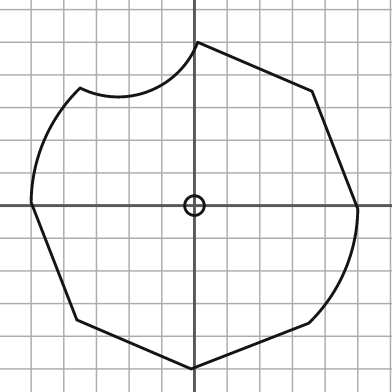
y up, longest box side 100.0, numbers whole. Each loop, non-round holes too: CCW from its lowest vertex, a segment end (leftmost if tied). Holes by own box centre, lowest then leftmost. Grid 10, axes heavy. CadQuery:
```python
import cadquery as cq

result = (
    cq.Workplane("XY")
    .moveTo(-1.0, -50.0)
    .lineTo(35.0, -36.0)
    .threePointArc((46.0, -20.0), (50.0, -1.0))
    .lineTo(36.0, 35.0)
    .lineTo(1.0, 50.0)
    .threePointArc((-14.0, 35.0), (-35.0, 36.0))
    .threePointArc((-46.0, 20.0), (-50.0, 1.0))
    .lineTo(-36.0, -35.0)
    .close()
    .moveTo(0.0, 0.0)
    .circle(3.0)
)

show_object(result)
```